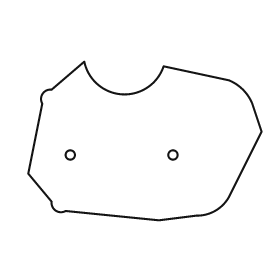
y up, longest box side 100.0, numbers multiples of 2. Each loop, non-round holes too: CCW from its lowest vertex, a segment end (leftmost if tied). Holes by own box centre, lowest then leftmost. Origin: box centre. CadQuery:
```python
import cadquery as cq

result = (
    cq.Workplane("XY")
    .moveTo(6.0, -34.0)
    .lineTo(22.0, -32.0)
    .threePointArc((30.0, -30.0), (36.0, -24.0))
    .lineTo(50.0, 4.0)
    .lineTo(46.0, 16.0)
    .threePointArc((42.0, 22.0), (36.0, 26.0))
    .lineTo(8.0, 32.0)
    .threePointArc((-10.0, 20.0), (-26.0, 34.0))
    .lineTo(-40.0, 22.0)
    .threePointArc((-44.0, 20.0), (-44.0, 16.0))
    .lineTo(-50.0, -14.0)
    .lineTo(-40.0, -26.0)
    .threePointArc((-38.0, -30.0), (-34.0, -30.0))
    .close()
    .moveTo(-32.0, -6.0)
    .circle(2.0)
    .moveTo(12.0, -6.0)
    .circle(2.0)
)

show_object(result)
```